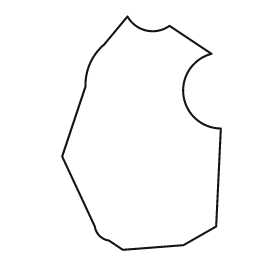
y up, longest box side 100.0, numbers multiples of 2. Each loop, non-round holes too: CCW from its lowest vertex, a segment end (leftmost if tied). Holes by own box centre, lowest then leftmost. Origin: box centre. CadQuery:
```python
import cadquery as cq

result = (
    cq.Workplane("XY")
    .moveTo(-8.0, -50.0)
    .lineTo(18.0, -48.0)
    .lineTo(32.0, -40.0)
    .lineTo(34.0, 2.0)
    .threePointArc((18.0, 16.0), (30.0, 34.0))
    .lineTo(12.0, 46.0)
    .threePointArc((2.0, 44.0), (-6.0, 50.0))
    .lineTo(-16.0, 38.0)
    .threePointArc((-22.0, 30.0), (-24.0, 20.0))
    .lineTo(-34.0, -10.0)
    .lineTo(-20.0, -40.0)
    .threePointArc((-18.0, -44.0), (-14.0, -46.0))
    .close()
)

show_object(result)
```